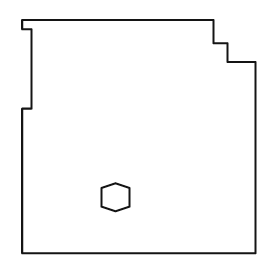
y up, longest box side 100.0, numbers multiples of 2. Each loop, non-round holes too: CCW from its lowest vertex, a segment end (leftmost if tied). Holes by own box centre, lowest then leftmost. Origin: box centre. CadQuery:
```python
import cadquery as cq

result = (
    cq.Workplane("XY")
    .moveTo(-50.0, -50.0)
    .lineTo(50.0, -50.0)
    .lineTo(50.0, 32.0)
    .lineTo(38.0, 32.0)
    .lineTo(38.0, 40.0)
    .lineTo(32.0, 40.0)
    .lineTo(32.0, 50.0)
    .lineTo(-50.0, 50.0)
    .lineTo(-50.0, 46.0)
    .lineTo(-46.0, 46.0)
    .lineTo(-46.0, 12.0)
    .lineTo(-50.0, 12.0)
    .close()
    .moveTo(-10.0, -32.0)
    .lineTo(-4.0, -30.0)
    .lineTo(-4.0, -22.0)
    .lineTo(-10.0, -20.0)
    .lineTo(-16.0, -22.0)
    .lineTo(-16.0, -30.0)
    .close()
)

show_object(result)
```